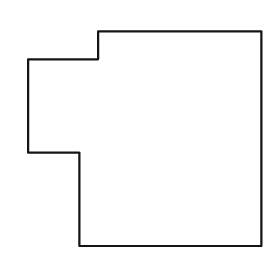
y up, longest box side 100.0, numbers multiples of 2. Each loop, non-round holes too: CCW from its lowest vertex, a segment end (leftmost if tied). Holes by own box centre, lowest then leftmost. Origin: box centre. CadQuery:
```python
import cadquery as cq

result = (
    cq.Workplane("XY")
    .moveTo(-28.0, -46.0)
    .lineTo(50.0, -46.0)
    .lineTo(50.0, 46.0)
    .lineTo(-20.0, 46.0)
    .lineTo(-20.0, 34.0)
    .lineTo(-50.0, 34.0)
    .lineTo(-50.0, -6.0)
    .lineTo(-28.0, -6.0)
    .close()
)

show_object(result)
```